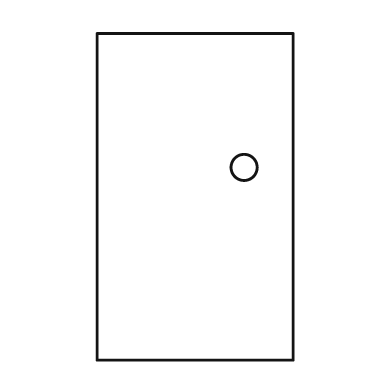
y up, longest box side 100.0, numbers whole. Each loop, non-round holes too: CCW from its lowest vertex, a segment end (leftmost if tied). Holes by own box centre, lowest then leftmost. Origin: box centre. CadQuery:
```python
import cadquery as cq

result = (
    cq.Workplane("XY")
    .moveTo(-30.0, -50.0)
    .lineTo(30.0, -50.0)
    .lineTo(30.0, 50.0)
    .lineTo(-30.0, 50.0)
    .close()
    .moveTo(15.0, 9.0)
    .circle(4.0)
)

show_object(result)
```